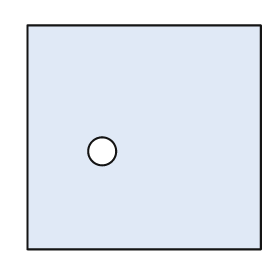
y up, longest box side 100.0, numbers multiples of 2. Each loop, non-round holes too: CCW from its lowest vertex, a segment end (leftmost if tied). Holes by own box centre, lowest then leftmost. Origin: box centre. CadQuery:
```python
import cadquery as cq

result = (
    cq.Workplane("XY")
    .moveTo(-50.0, -48.0)
    .lineTo(50.0, -48.0)
    .lineTo(50.0, 48.0)
    .lineTo(-50.0, 48.0)
    .close()
    .moveTo(-18.0, -6.0)
    .circle(6.0)
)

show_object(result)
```